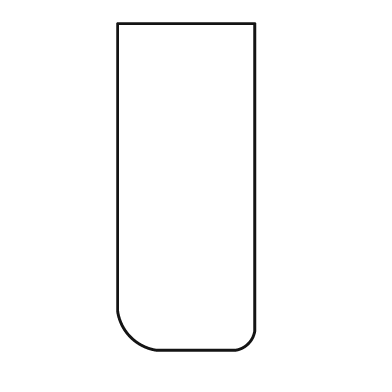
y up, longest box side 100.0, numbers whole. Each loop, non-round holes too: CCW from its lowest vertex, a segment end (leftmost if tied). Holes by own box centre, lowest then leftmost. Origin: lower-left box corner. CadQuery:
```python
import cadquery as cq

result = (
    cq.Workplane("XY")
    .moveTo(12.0, 0.0)
    .lineTo(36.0, 0.0)
    .threePointArc((40.0, 2.0), (42.0, 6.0))
    .lineTo(42.0, 100.0)
    .lineTo(0.0, 100.0)
    .lineTo(0.0, 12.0)
    .threePointArc((4.0, 4.0), (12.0, 0.0))
    .close()
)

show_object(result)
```